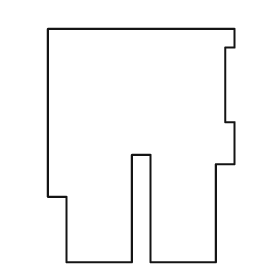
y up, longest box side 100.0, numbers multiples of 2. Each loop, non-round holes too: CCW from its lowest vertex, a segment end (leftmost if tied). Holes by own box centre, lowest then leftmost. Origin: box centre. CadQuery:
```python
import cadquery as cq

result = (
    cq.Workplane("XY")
    .moveTo(-32.0, -50.0)
    .lineTo(-4.0, -50.0)
    .lineTo(-4.0, -4.0)
    .lineTo(4.0, -4.0)
    .lineTo(4.0, -50.0)
    .lineTo(32.0, -50.0)
    .lineTo(32.0, -8.0)
    .lineTo(40.0, -8.0)
    .lineTo(40.0, 10.0)
    .lineTo(36.0, 10.0)
    .lineTo(36.0, 42.0)
    .lineTo(40.0, 42.0)
    .lineTo(40.0, 50.0)
    .lineTo(-40.0, 50.0)
    .lineTo(-40.0, -22.0)
    .lineTo(-32.0, -22.0)
    .close()
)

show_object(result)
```